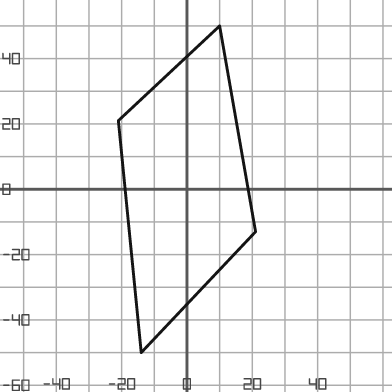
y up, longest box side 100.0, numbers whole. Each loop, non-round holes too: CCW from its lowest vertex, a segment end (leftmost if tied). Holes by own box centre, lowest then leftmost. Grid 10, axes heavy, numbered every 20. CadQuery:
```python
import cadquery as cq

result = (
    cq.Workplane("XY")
    .moveTo(-14.0, -50.0)
    .lineTo(21.0, -13.0)
    .lineTo(10.0, 50.0)
    .lineTo(-21.0, 21.0)
    .close()
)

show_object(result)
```